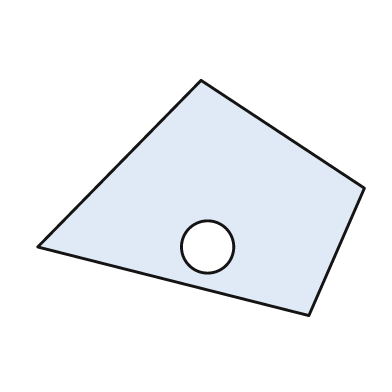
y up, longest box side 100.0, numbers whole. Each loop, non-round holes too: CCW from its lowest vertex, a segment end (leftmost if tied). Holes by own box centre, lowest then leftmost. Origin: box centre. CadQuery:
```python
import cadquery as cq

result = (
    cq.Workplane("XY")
    .moveTo(33.0, -36.0)
    .lineTo(50.0, 3.0)
    .lineTo(0.0, 36.0)
    .lineTo(-50.0, -15.0)
    .close()
    .moveTo(2.0, -15.0)
    .circle(8.0)
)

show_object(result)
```